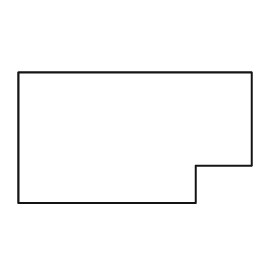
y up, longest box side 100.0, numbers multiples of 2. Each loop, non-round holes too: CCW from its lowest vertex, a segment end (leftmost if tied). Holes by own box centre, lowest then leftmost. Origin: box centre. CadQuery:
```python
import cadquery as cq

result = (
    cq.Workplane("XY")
    .moveTo(-50.0, -28.0)
    .lineTo(26.0, -28.0)
    .lineTo(26.0, -12.0)
    .lineTo(50.0, -12.0)
    .lineTo(50.0, 28.0)
    .lineTo(-50.0, 28.0)
    .close()
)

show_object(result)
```